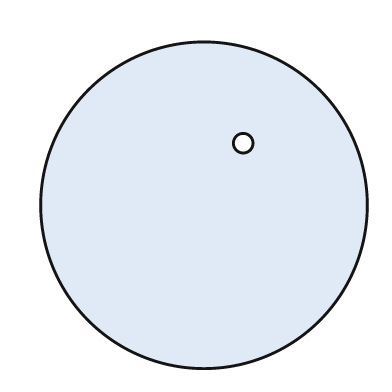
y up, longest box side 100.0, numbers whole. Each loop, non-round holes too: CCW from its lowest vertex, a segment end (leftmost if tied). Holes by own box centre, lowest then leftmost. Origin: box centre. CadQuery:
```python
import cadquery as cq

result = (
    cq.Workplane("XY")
    .moveTo(0.0, 0.0)
    .circle(50.0)
    .moveTo(12.0, 19.0)
    .circle(3.0)
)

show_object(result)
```